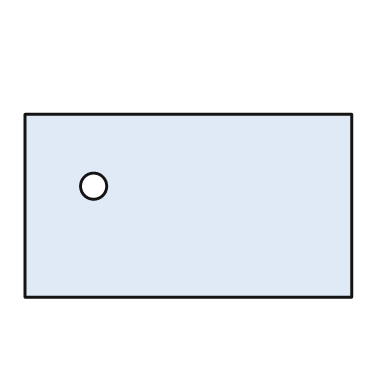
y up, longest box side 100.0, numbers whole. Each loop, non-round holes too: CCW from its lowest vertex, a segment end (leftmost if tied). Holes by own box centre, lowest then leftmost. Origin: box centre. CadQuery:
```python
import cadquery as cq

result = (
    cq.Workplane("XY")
    .moveTo(-50.0, -28.0)
    .lineTo(50.0, -28.0)
    .lineTo(50.0, 28.0)
    .lineTo(-50.0, 28.0)
    .close()
    .moveTo(-29.0, 6.0)
    .circle(4.0)
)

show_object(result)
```